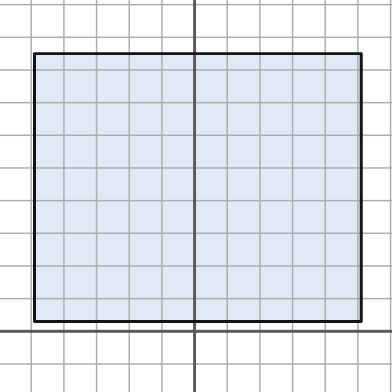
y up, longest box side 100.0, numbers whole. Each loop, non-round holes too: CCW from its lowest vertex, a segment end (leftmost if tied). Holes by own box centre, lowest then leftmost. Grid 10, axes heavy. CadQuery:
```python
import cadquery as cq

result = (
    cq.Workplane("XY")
    .moveTo(-49.0, 3.0)
    .lineTo(51.0, 3.0)
    .lineTo(51.0, 85.0)
    .lineTo(-49.0, 85.0)
    .close()
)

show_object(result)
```